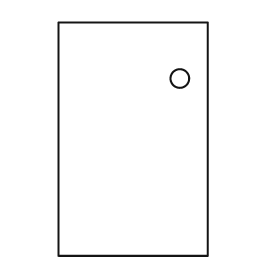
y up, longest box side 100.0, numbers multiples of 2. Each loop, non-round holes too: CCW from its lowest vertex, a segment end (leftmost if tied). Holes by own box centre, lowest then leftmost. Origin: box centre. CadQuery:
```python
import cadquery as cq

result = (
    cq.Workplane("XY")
    .moveTo(-32.0, -50.0)
    .lineTo(32.0, -50.0)
    .lineTo(32.0, 50.0)
    .lineTo(-32.0, 50.0)
    .close()
    .moveTo(20.0, 26.0)
    .circle(4.0)
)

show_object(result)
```